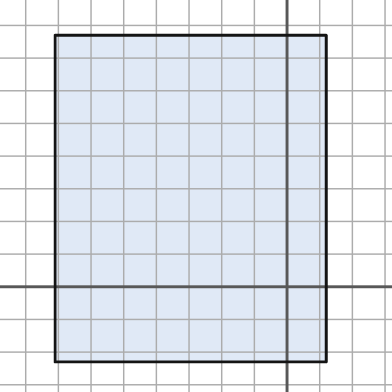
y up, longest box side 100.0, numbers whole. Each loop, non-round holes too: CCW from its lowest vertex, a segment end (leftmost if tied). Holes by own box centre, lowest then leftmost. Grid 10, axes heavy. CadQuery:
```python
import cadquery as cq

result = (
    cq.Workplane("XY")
    .moveTo(-71.0, -23.0)
    .lineTo(12.0, -23.0)
    .lineTo(12.0, 77.0)
    .lineTo(-71.0, 77.0)
    .close()
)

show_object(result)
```